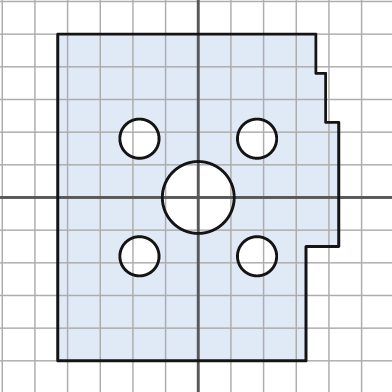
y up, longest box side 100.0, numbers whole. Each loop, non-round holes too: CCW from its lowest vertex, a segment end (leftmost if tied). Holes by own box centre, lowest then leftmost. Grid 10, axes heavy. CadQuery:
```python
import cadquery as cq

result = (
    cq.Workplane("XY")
    .moveTo(-43.0, -50.0)
    .lineTo(33.0, -50.0)
    .lineTo(33.0, -15.0)
    .lineTo(43.0, -15.0)
    .lineTo(43.0, 23.0)
    .lineTo(39.0, 23.0)
    .lineTo(39.0, 38.0)
    .lineTo(36.0, 38.0)
    .lineTo(36.0, 50.0)
    .lineTo(-43.0, 50.0)
    .close()
    .moveTo(-18.0, -18.0)
    .circle(6.0)
    .moveTo(18.0, -18.0)
    .circle(6.0)
    .moveTo(0.0, 0.0)
    .circle(11.0)
    .moveTo(-18.0, 18.0)
    .circle(6.0)
    .moveTo(18.0, 18.0)
    .circle(6.0)
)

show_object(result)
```